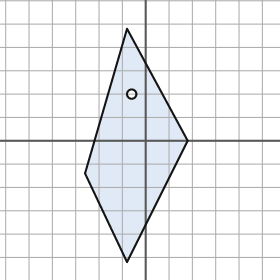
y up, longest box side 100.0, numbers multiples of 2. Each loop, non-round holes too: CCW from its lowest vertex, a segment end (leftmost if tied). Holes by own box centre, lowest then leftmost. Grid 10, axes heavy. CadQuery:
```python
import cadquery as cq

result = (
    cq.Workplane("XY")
    .moveTo(-8.0, -52.0)
    .lineTo(18.0, 0.0)
    .lineTo(-8.0, 48.0)
    .lineTo(-26.0, -14.0)
    .close()
    .moveTo(-6.0, 20.0)
    .circle(2.0)
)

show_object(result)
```